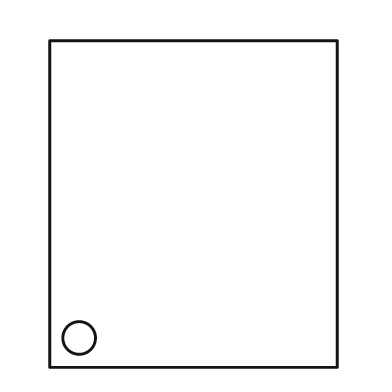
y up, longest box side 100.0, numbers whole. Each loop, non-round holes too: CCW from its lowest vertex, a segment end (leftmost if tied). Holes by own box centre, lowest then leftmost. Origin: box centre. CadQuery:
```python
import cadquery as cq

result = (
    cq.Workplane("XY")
    .moveTo(-44.0, -50.0)
    .lineTo(44.0, -50.0)
    .lineTo(44.0, 50.0)
    .lineTo(-44.0, 50.0)
    .close()
    .moveTo(-35.0, -41.0)
    .circle(5.0)
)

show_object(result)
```